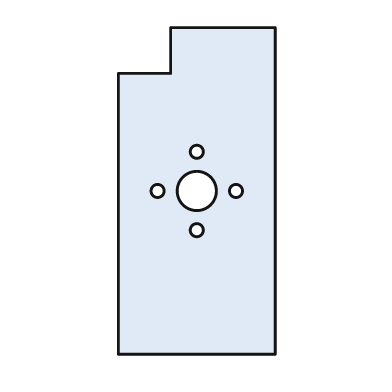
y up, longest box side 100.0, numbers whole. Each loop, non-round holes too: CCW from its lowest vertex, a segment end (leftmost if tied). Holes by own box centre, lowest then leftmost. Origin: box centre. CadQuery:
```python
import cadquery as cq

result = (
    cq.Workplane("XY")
    .moveTo(-24.0, -50.0)
    .lineTo(24.0, -50.0)
    .lineTo(24.0, 50.0)
    .lineTo(-8.0, 50.0)
    .lineTo(-8.0, 36.0)
    .lineTo(-24.0, 36.0)
    .close()
    .moveTo(0.0, -12.0)
    .circle(2.0)
    .moveTo(-12.0, 0.0)
    .circle(2.0)
    .moveTo(0.0, 0.0)
    .circle(6.0)
    .moveTo(12.0, 0.0)
    .circle(2.0)
    .moveTo(0.0, 12.0)
    .circle(2.0)
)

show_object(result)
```